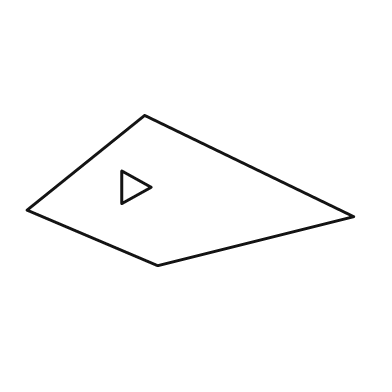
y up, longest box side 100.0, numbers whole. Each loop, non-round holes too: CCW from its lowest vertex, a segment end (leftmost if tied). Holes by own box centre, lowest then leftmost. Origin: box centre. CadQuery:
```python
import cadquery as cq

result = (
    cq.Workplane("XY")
    .moveTo(-10.0, -23.0)
    .lineTo(50.0, -8.0)
    .lineTo(-14.0, 23.0)
    .lineTo(-50.0, -6.0)
    .close()
    .moveTo(-21.0, -4.0)
    .lineTo(-12.0, 1.0)
    .lineTo(-21.0, 6.0)
    .close()
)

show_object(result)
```